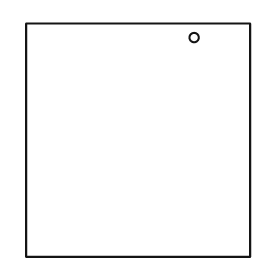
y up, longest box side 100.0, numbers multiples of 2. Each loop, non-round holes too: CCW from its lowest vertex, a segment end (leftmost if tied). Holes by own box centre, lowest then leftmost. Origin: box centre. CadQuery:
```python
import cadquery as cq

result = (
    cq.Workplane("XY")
    .moveTo(-48.0, -50.0)
    .lineTo(48.0, -50.0)
    .lineTo(48.0, 50.0)
    .lineTo(-48.0, 50.0)
    .close()
    .moveTo(24.0, 44.0)
    .circle(2.0)
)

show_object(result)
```